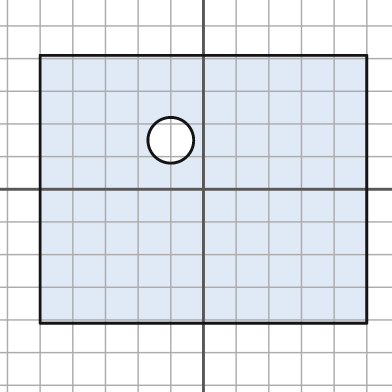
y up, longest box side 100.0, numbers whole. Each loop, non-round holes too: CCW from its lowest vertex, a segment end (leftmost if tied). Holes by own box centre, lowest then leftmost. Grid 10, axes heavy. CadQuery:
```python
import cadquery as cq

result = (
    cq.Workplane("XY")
    .moveTo(-50.0, -41.0)
    .lineTo(50.0, -41.0)
    .lineTo(50.0, 41.0)
    .lineTo(-50.0, 41.0)
    .close()
    .moveTo(-10.0, 15.0)
    .circle(7.0)
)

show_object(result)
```